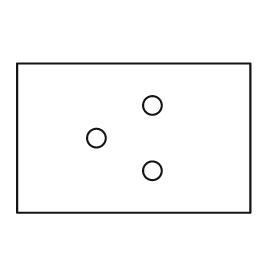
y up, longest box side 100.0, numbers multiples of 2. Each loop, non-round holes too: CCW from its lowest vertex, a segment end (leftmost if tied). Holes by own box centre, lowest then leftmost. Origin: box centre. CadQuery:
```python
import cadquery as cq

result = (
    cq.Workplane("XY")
    .moveTo(-50.0, -32.0)
    .lineTo(50.0, -32.0)
    .lineTo(50.0, 32.0)
    .lineTo(-50.0, 32.0)
    .close()
    .moveTo(8.0, -14.0)
    .circle(4.0)
    .moveTo(-16.0, 0.0)
    .circle(4.0)
    .moveTo(8.0, 14.0)
    .circle(4.0)
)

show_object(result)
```